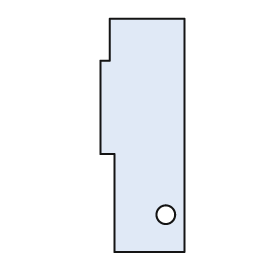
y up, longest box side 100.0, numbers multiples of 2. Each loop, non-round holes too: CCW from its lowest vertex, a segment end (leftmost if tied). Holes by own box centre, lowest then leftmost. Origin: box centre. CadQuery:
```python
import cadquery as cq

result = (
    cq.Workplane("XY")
    .moveTo(-12.0, -50.0)
    .lineTo(18.0, -50.0)
    .lineTo(18.0, 50.0)
    .lineTo(-14.0, 50.0)
    .lineTo(-14.0, 32.0)
    .lineTo(-18.0, 32.0)
    .lineTo(-18.0, -8.0)
    .lineTo(-12.0, -8.0)
    .close()
    .moveTo(10.0, -34.0)
    .circle(4.0)
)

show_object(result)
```